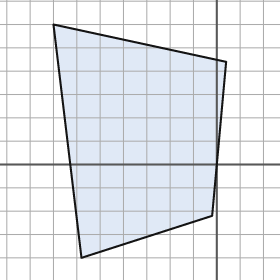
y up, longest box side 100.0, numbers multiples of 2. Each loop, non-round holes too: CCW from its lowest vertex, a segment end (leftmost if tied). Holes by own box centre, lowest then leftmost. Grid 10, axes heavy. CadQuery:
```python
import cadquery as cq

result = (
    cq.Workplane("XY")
    .moveTo(-58.0, -40.0)
    .lineTo(-2.0, -22.0)
    .lineTo(4.0, 44.0)
    .lineTo(-70.0, 60.0)
    .close()
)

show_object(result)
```